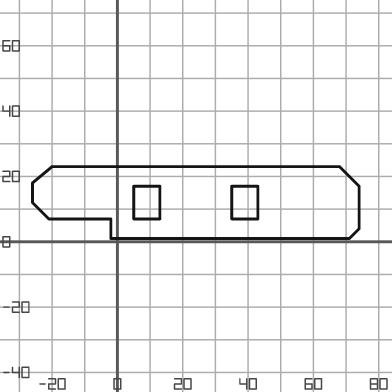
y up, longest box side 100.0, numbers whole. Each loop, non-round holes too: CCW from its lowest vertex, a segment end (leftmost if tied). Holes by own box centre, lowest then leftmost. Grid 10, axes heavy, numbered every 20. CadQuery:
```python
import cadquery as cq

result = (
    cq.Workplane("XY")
    .moveTo(-2.0, 1.0)
    .lineTo(71.0, 1.0)
    .lineTo(74.0, 4.0)
    .lineTo(74.0, 17.0)
    .lineTo(68.0, 23.0)
    .lineTo(-20.0, 23.0)
    .lineTo(-26.0, 18.0)
    .lineTo(-26.0, 12.0)
    .lineTo(-21.0, 7.0)
    .lineTo(-2.0, 7.0)
    .close()
    .moveTo(5.0, 7.0)
    .lineTo(13.0, 7.0)
    .lineTo(13.0, 17.0)
    .lineTo(5.0, 17.0)
    .close()
    .moveTo(35.0, 7.0)
    .lineTo(43.0, 7.0)
    .lineTo(43.0, 17.0)
    .lineTo(35.0, 17.0)
    .close()
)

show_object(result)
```